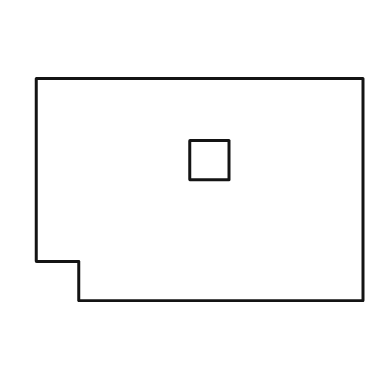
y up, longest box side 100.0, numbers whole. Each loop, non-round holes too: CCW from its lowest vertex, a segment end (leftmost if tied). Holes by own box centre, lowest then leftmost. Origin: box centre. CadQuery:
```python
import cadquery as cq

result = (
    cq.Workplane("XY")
    .moveTo(-37.0, -34.0)
    .lineTo(50.0, -34.0)
    .lineTo(50.0, 34.0)
    .lineTo(-50.0, 34.0)
    .lineTo(-50.0, -22.0)
    .lineTo(-37.0, -22.0)
    .close()
    .moveTo(-3.0, 3.0)
    .lineTo(9.0, 3.0)
    .lineTo(9.0, 15.0)
    .lineTo(-3.0, 15.0)
    .close()
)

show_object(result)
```